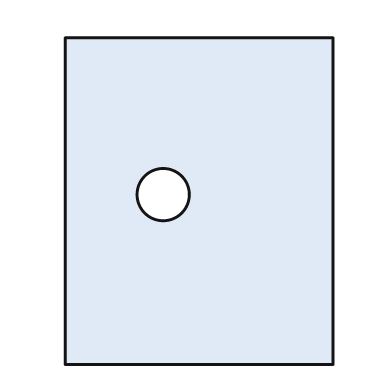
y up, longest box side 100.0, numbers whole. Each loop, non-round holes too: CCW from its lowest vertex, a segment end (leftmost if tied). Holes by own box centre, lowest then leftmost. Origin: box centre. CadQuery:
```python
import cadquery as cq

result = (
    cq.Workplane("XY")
    .moveTo(-41.0, -50.0)
    .lineTo(41.0, -50.0)
    .lineTo(41.0, 50.0)
    .lineTo(-41.0, 50.0)
    .close()
    .moveTo(-11.0, 2.0)
    .circle(8.0)
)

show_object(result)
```